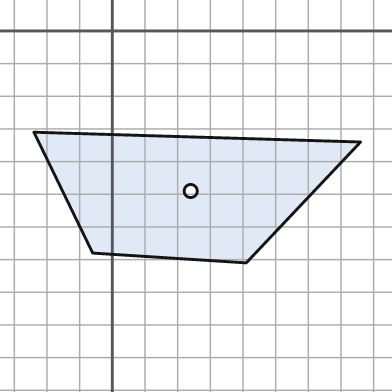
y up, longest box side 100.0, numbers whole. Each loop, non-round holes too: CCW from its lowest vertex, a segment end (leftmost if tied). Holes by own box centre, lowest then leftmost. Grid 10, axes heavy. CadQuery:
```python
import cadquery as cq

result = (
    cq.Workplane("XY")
    .moveTo(41.0, -71.0)
    .lineTo(76.0, -34.0)
    .lineTo(-24.0, -31.0)
    .lineTo(-6.0, -68.0)
    .close()
    .moveTo(24.0, -49.0)
    .circle(2.0)
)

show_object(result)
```